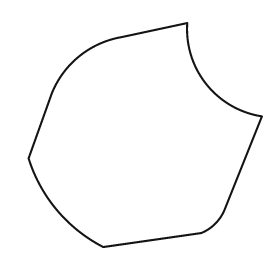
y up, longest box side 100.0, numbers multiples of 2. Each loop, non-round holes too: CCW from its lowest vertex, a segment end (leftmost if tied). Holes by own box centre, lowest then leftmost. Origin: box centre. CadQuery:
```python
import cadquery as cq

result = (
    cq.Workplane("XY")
    .moveTo(-18.0, -48.0)
    .lineTo(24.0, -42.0)
    .threePointArc((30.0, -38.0), (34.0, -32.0))
    .lineTo(50.0, 8.0)
    .threePointArc((26.0, 22.0), (18.0, 48.0))
    .lineTo(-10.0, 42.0)
    .threePointArc((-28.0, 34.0), (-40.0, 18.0))
    .lineTo(-50.0, -10.0)
    .threePointArc((-38.0, -32.0), (-18.0, -48.0))
    .close()
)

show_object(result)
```